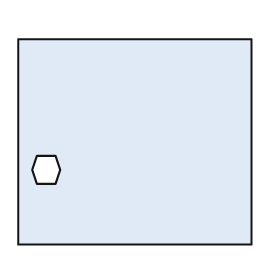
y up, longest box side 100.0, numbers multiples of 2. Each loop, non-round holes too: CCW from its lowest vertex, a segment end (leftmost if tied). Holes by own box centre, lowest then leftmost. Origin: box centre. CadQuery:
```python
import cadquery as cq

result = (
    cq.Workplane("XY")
    .moveTo(-50.0, -44.0)
    .lineTo(50.0, -44.0)
    .lineTo(50.0, 44.0)
    .lineTo(-50.0, 44.0)
    .close()
    .moveTo(-42.0, -18.0)
    .lineTo(-34.0, -18.0)
    .lineTo(-32.0, -12.0)
    .lineTo(-34.0, -6.0)
    .lineTo(-42.0, -6.0)
    .lineTo(-44.0, -12.0)
    .close()
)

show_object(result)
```